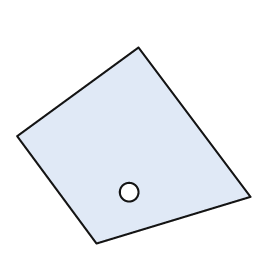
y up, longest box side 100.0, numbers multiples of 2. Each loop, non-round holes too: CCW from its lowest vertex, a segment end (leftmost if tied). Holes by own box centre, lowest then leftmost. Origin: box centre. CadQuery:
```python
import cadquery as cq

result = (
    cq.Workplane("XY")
    .moveTo(-16.0, -42.0)
    .lineTo(50.0, -22.0)
    .lineTo(2.0, 42.0)
    .lineTo(-50.0, 4.0)
    .close()
    .moveTo(-2.0, -20.0)
    .circle(4.0)
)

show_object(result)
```